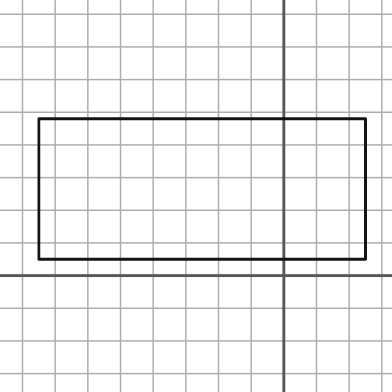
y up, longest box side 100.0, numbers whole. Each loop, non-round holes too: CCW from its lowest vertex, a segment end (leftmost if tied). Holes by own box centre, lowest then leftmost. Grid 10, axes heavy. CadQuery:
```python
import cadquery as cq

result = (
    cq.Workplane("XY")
    .moveTo(-75.0, 5.0)
    .lineTo(25.0, 5.0)
    .lineTo(25.0, 48.0)
    .lineTo(-75.0, 48.0)
    .close()
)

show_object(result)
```